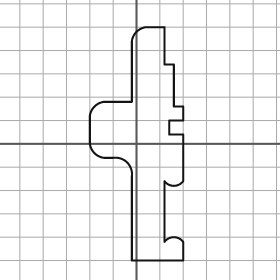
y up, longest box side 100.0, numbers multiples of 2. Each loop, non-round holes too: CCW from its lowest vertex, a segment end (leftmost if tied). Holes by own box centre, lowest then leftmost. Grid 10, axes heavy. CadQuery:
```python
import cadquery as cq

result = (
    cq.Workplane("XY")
    .moveTo(-2.0, -50.0)
    .lineTo(20.0, -50.0)
    .lineTo(20.0, -42.0)
    .threePointArc((16.0, -40.0), (12.0, -42.0))
    .lineTo(12.0, -16.0)
    .threePointArc((16.0, -18.0), (20.0, -16.0))
    .lineTo(20.0, 4.0)
    .lineTo(14.0, 4.0)
    .lineTo(14.0, 10.0)
    .lineTo(20.0, 10.0)
    .lineTo(20.0, 16.0)
    .lineTo(16.0, 16.0)
    .lineTo(16.0, 34.0)
    .lineTo(12.0, 34.0)
    .lineTo(12.0, 50.0)
    .lineTo(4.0, 50.0)
    .threePointArc((0.0, 48.0), (-2.0, 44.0))
    .lineTo(-2.0, 18.0)
    .lineTo(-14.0, 18.0)
    .threePointArc((-18.0, 16.0), (-20.0, 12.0))
    .lineTo(-20.0, 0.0)
    .threePointArc((-18.0, -4.0), (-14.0, -6.0))
    .lineTo(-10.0, -6.0)
    .threePointArc((-4.0, -8.0), (-2.0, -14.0))
    .close()
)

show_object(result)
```